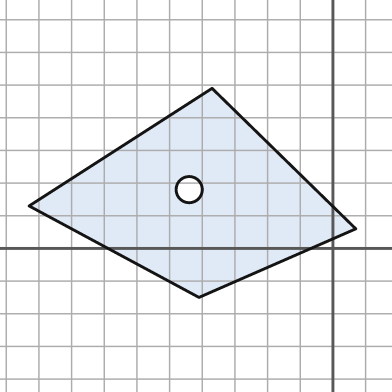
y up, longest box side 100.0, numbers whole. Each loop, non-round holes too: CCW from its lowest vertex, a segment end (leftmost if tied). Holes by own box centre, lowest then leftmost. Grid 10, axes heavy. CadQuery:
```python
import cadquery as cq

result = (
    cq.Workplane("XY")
    .moveTo(-41.0, -15.0)
    .lineTo(7.0, 6.0)
    .lineTo(-37.0, 49.0)
    .lineTo(-93.0, 13.0)
    .close()
    .moveTo(-44.0, 18.0)
    .circle(4.0)
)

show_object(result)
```